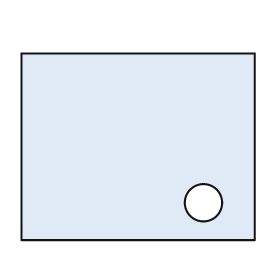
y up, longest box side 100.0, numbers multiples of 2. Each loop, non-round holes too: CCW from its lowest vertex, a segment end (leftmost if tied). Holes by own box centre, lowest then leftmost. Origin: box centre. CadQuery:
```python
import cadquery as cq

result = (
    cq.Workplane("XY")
    .moveTo(-50.0, -40.0)
    .lineTo(50.0, -40.0)
    .lineTo(50.0, 40.0)
    .lineTo(-50.0, 40.0)
    .close()
    .moveTo(28.0, -24.0)
    .circle(8.0)
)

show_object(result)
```